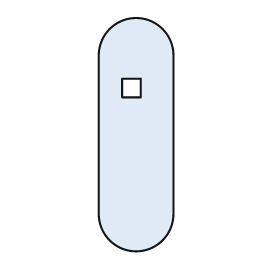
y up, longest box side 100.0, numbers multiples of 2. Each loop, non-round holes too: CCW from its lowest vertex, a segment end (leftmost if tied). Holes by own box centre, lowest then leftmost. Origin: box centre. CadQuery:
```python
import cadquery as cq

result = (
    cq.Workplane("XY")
    .moveTo(-16.0, -34.0)
    .threePointArc((0.0, -50.0), (16.0, -34.0))
    .lineTo(16.0, 34.0)
    .threePointArc((0.0, 50.0), (-16.0, 34.0))
    .close()
    .moveTo(-6.0, 16.0)
    .lineTo(2.0, 16.0)
    .lineTo(2.0, 24.0)
    .lineTo(-6.0, 24.0)
    .close()
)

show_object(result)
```